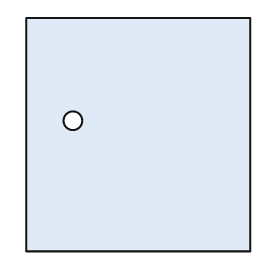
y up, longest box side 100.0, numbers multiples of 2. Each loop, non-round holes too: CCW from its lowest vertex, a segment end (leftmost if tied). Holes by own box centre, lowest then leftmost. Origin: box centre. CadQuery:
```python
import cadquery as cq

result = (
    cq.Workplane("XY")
    .moveTo(-48.0, -50.0)
    .lineTo(48.0, -50.0)
    .lineTo(48.0, 50.0)
    .lineTo(-48.0, 50.0)
    .close()
    .moveTo(-28.0, 6.0)
    .circle(4.0)
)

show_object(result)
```